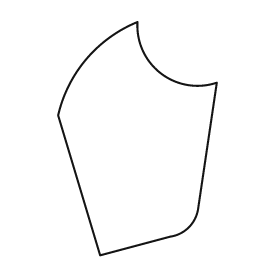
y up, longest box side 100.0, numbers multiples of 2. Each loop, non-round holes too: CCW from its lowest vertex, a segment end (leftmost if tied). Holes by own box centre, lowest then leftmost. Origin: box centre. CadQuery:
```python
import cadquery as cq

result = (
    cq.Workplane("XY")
    .moveTo(-16.0, -50.0)
    .lineTo(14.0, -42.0)
    .threePointArc((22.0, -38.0), (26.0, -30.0))
    .lineTo(34.0, 24.0)
    .threePointArc((10.0, 28.0), (0.0, 50.0))
    .threePointArc((-22.0, 34.0), (-34.0, 10.0))
    .close()
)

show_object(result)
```